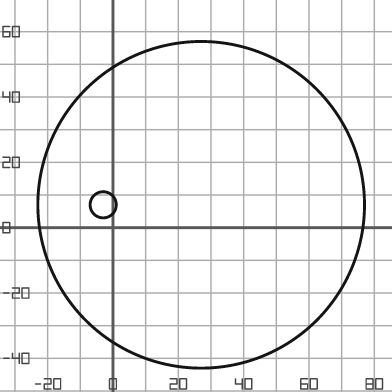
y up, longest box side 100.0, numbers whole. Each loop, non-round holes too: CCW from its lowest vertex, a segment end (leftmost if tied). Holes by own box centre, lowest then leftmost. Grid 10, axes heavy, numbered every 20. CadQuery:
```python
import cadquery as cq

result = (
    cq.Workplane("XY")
    .moveTo(27.0, 7.0)
    .circle(50.0)
    .moveTo(-3.0, 7.0)
    .circle(4.0)
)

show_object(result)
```